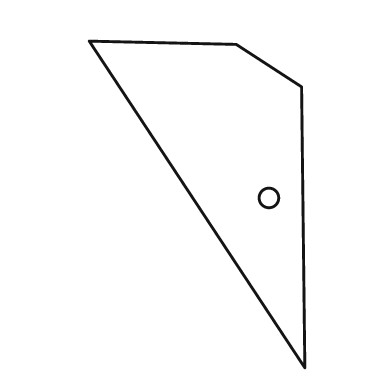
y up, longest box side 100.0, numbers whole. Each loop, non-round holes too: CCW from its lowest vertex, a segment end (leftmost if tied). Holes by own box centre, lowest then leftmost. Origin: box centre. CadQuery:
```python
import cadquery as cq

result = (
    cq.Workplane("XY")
    .moveTo(33.0, -50.0)
    .lineTo(32.0, 36.0)
    .lineTo(12.0, 49.0)
    .lineTo(-33.0, 50.0)
    .close()
    .moveTo(22.0, 2.0)
    .circle(3.0)
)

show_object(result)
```